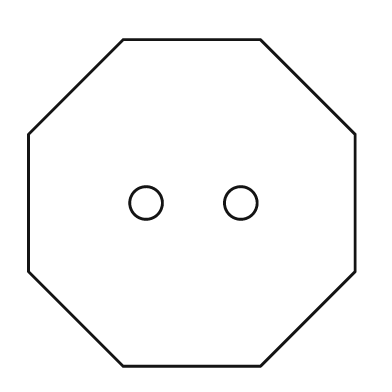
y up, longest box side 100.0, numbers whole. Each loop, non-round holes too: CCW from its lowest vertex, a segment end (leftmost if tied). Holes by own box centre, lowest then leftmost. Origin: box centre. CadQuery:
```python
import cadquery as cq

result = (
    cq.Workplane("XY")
    .moveTo(-21.0, -50.0)
    .lineTo(21.0, -50.0)
    .lineTo(50.0, -21.0)
    .lineTo(50.0, 21.0)
    .lineTo(21.0, 50.0)
    .lineTo(-21.0, 50.0)
    .lineTo(-50.0, 21.0)
    .lineTo(-50.0, -21.0)
    .close()
    .moveTo(-14.0, 0.0)
    .circle(5.0)
    .moveTo(15.0, 0.0)
    .circle(5.0)
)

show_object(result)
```